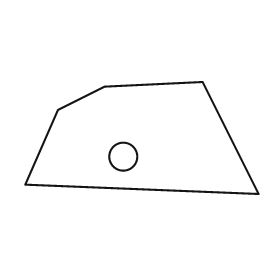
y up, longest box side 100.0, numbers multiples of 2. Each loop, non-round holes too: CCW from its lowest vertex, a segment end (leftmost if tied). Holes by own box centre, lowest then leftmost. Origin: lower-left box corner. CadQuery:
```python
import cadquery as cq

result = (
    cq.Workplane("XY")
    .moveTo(100.0, 0.0)
    .lineTo(76.0, 48.0)
    .lineTo(34.0, 46.0)
    .lineTo(14.0, 36.0)
    .lineTo(0.0, 4.0)
    .close()
    .moveTo(42.0, 16.0)
    .circle(6.0)
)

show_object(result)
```